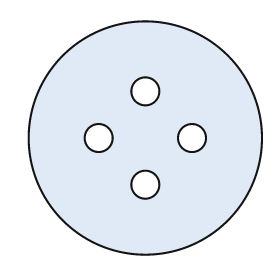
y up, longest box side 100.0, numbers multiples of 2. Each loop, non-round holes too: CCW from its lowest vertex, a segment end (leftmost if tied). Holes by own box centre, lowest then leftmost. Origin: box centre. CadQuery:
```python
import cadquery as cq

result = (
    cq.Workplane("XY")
    .moveTo(0.0, 0.0)
    .circle(50.0)
    .moveTo(0.0, -20.0)
    .circle(6.0)
    .moveTo(-20.0, 0.0)
    .circle(6.0)
    .moveTo(20.0, 0.0)
    .circle(6.0)
    .moveTo(0.0, 20.0)
    .circle(6.0)
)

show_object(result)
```